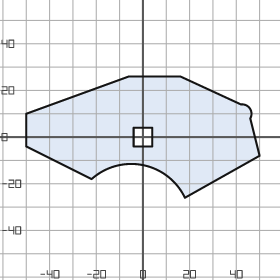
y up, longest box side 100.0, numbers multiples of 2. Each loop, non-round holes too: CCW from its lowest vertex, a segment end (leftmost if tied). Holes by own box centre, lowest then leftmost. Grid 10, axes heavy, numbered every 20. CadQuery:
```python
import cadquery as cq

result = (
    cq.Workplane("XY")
    .moveTo(18.0, -26.0)
    .lineTo(50.0, -8.0)
    .lineTo(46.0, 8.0)
    .threePointArc((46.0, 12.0), (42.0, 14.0))
    .lineTo(16.0, 26.0)
    .lineTo(-6.0, 26.0)
    .lineTo(-50.0, 10.0)
    .lineTo(-50.0, -4.0)
    .lineTo(-22.0, -18.0)
    .threePointArc((0.0, -12.0), (18.0, -26.0))
    .close()
    .moveTo(-4.0, -4.0)
    .lineTo(4.0, -4.0)
    .lineTo(4.0, 4.0)
    .lineTo(-4.0, 4.0)
    .close()
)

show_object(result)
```